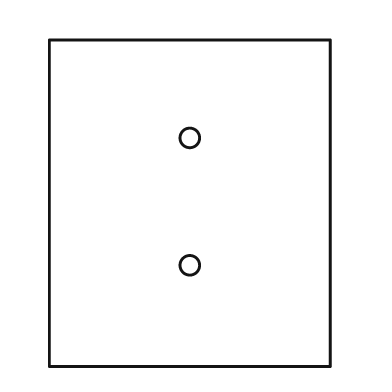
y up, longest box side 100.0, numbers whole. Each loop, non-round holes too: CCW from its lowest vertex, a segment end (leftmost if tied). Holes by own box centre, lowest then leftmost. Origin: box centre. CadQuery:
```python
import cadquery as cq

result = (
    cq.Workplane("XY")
    .moveTo(-43.0, -50.0)
    .lineTo(43.0, -50.0)
    .lineTo(43.0, 50.0)
    .lineTo(-43.0, 50.0)
    .close()
    .moveTo(0.0, -19.0)
    .circle(3.0)
    .moveTo(0.0, 20.0)
    .circle(3.0)
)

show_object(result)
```